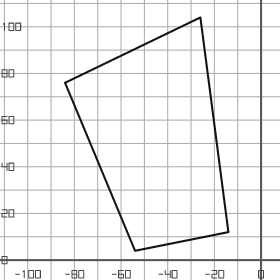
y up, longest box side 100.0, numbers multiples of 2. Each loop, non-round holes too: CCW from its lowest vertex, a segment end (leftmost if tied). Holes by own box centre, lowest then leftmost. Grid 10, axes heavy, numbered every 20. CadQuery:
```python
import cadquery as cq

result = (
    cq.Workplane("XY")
    .moveTo(-54.0, 4.0)
    .lineTo(-14.0, 12.0)
    .lineTo(-26.0, 104.0)
    .lineTo(-84.0, 76.0)
    .close()
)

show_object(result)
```